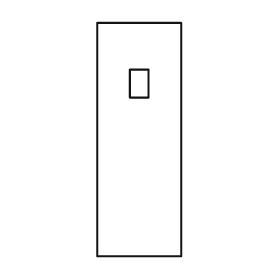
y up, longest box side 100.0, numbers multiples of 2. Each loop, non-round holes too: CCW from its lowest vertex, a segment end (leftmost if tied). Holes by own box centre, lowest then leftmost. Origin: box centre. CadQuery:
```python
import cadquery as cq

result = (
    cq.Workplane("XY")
    .moveTo(-18.0, -50.0)
    .lineTo(18.0, -50.0)
    .lineTo(18.0, 50.0)
    .lineTo(-18.0, 50.0)
    .close()
    .moveTo(-4.0, 18.0)
    .lineTo(4.0, 18.0)
    .lineTo(4.0, 30.0)
    .lineTo(-4.0, 30.0)
    .close()
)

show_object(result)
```